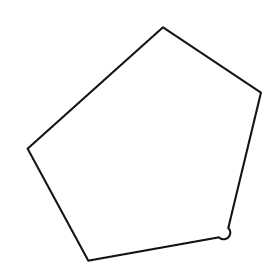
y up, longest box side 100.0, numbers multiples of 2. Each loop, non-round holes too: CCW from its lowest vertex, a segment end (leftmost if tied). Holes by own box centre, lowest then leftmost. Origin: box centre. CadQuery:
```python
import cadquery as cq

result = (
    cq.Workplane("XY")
    .moveTo(-24.0, -50.0)
    .lineTo(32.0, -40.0)
    .threePointArc((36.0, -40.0), (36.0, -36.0))
    .lineTo(50.0, 22.0)
    .lineTo(8.0, 50.0)
    .lineTo(-50.0, -2.0)
    .close()
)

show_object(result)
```